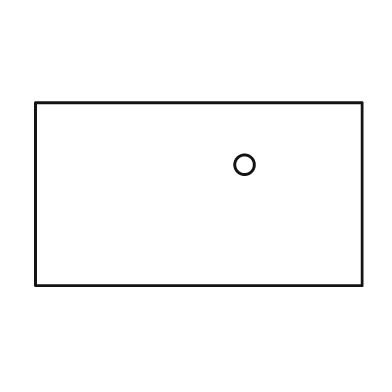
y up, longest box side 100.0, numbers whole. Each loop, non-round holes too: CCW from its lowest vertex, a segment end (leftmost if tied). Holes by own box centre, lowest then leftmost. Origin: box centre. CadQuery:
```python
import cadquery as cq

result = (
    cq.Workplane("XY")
    .moveTo(-50.0, -28.0)
    .lineTo(50.0, -28.0)
    .lineTo(50.0, 28.0)
    .lineTo(-50.0, 28.0)
    .close()
    .moveTo(14.0, 9.0)
    .circle(3.0)
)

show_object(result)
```